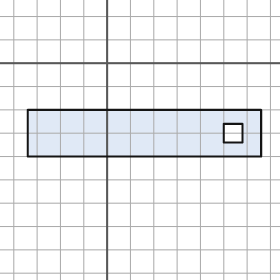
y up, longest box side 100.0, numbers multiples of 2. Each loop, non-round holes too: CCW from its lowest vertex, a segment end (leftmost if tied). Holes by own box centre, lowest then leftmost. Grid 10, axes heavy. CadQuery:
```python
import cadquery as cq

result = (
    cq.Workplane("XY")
    .moveTo(-34.0, -40.0)
    .lineTo(66.0, -40.0)
    .lineTo(66.0, -20.0)
    .lineTo(-34.0, -20.0)
    .close()
    .moveTo(50.0, -34.0)
    .lineTo(58.0, -34.0)
    .lineTo(58.0, -26.0)
    .lineTo(50.0, -26.0)
    .close()
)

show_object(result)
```